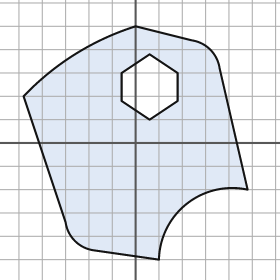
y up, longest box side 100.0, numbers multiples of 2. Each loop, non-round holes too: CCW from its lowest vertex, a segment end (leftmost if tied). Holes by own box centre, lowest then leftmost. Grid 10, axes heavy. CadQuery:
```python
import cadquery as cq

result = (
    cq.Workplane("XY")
    .moveTo(10.0, -50.0)
    .threePointArc((22.0, -26.0), (48.0, -20.0))
    .lineTo(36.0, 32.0)
    .threePointArc((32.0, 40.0), (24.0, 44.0))
    .lineTo(0.0, 50.0)
    .threePointArc((-26.0, 38.0), (-48.0, 20.0))
    .lineTo(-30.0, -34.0)
    .threePointArc((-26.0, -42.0), (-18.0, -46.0))
    .close()
    .moveTo(6.0, 10.0)
    .lineTo(18.0, 18.0)
    .lineTo(18.0, 30.0)
    .lineTo(6.0, 38.0)
    .lineTo(-6.0, 30.0)
    .lineTo(-6.0, 18.0)
    .close()
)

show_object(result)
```